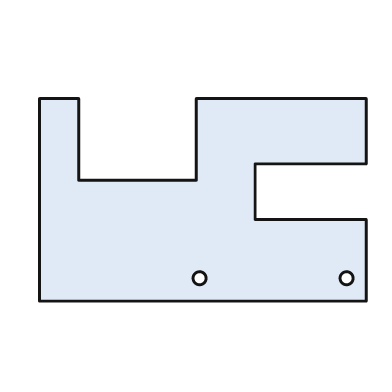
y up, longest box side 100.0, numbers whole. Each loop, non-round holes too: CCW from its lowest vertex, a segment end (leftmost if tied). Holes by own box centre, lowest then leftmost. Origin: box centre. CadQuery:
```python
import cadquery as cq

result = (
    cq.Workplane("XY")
    .moveTo(-50.0, -31.0)
    .lineTo(50.0, -31.0)
    .lineTo(50.0, -6.0)
    .lineTo(16.0, -6.0)
    .lineTo(16.0, 11.0)
    .lineTo(50.0, 11.0)
    .lineTo(50.0, 31.0)
    .lineTo(-2.0, 31.0)
    .lineTo(-2.0, 6.0)
    .lineTo(-38.0, 6.0)
    .lineTo(-38.0, 31.0)
    .lineTo(-50.0, 31.0)
    .close()
    .moveTo(-1.0, -24.0)
    .circle(2.0)
    .moveTo(44.0, -24.0)
    .circle(2.0)
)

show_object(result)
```